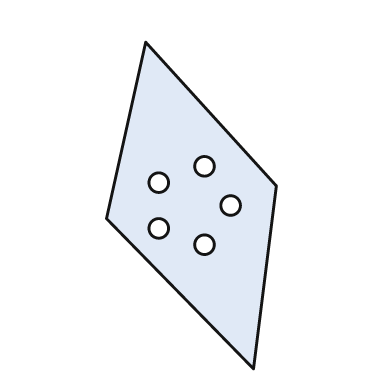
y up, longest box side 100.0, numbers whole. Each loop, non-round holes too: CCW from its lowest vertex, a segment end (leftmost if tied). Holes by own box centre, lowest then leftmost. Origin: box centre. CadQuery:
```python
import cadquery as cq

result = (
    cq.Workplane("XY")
    .moveTo(19.0, -50.0)
    .lineTo(26.0, 6.0)
    .lineTo(-14.0, 50.0)
    .lineTo(-26.0, -4.0)
    .close()
    .moveTo(4.0, -12.0)
    .circle(3.0)
    .moveTo(-10.0, -7.0)
    .circle(3.0)
    .moveTo(12.0, 0.0)
    .circle(3.0)
    .moveTo(-10.0, 7.0)
    .circle(3.0)
    .moveTo(4.0, 12.0)
    .circle(3.0)
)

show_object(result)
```